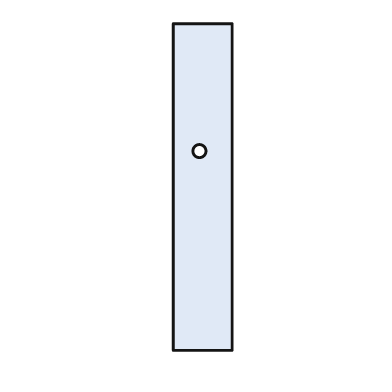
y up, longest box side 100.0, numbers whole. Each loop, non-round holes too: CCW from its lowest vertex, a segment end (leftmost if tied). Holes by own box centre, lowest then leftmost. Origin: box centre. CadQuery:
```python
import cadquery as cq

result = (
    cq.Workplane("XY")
    .moveTo(-9.0, -50.0)
    .lineTo(9.0, -50.0)
    .lineTo(9.0, 50.0)
    .lineTo(-9.0, 50.0)
    .close()
    .moveTo(-1.0, 11.0)
    .circle(2.0)
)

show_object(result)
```